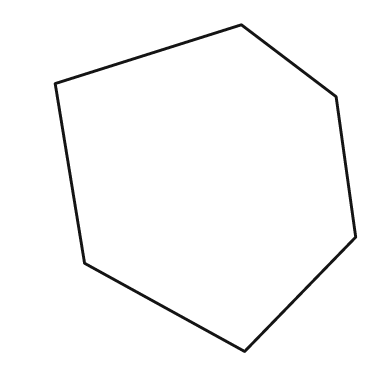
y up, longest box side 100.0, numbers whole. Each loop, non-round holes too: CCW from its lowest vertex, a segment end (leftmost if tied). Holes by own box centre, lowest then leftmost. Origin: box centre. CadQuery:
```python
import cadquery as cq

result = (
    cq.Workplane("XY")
    .moveTo(12.0, -50.0)
    .lineTo(46.0, -15.0)
    .lineTo(40.0, 28.0)
    .lineTo(11.0, 50.0)
    .lineTo(-46.0, 32.0)
    .lineTo(-37.0, -23.0)
    .close()
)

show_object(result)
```